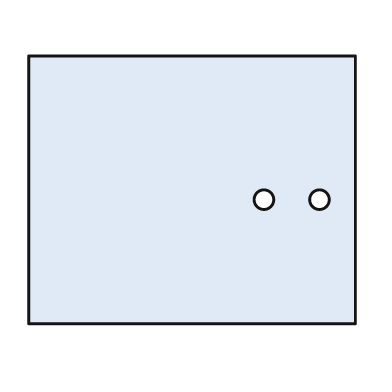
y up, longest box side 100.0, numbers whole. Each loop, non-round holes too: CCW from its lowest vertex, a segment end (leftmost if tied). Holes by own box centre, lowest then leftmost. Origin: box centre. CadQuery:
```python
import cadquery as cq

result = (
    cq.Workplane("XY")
    .moveTo(-50.0, -41.0)
    .lineTo(50.0, -41.0)
    .lineTo(50.0, 41.0)
    .lineTo(-50.0, 41.0)
    .close()
    .moveTo(22.0, -3.0)
    .circle(3.0)
    .moveTo(39.0, -3.0)
    .circle(3.0)
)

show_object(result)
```